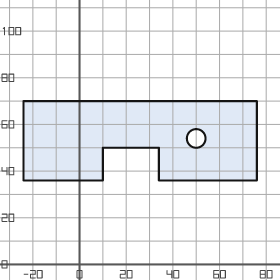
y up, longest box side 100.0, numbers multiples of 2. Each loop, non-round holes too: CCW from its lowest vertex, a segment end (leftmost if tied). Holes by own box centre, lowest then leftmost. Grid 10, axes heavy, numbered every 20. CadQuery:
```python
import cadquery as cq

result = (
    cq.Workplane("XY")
    .moveTo(-24.0, 36.0)
    .lineTo(10.0, 36.0)
    .lineTo(10.0, 50.0)
    .lineTo(34.0, 50.0)
    .lineTo(34.0, 36.0)
    .lineTo(76.0, 36.0)
    .lineTo(76.0, 70.0)
    .lineTo(-24.0, 70.0)
    .close()
    .moveTo(50.0, 54.0)
    .circle(4.0)
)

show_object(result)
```